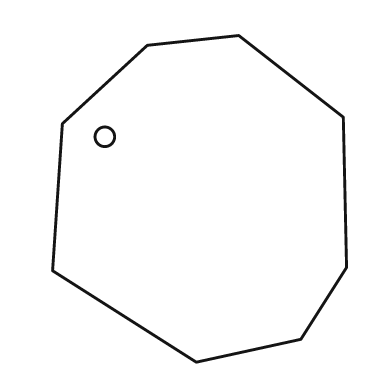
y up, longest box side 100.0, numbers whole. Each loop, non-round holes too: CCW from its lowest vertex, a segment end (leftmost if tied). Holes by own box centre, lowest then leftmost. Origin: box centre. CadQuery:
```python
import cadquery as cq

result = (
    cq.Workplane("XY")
    .moveTo(-1.0, -50.0)
    .lineTo(31.0, -43.0)
    .lineTo(45.0, -21.0)
    .lineTo(44.0, 25.0)
    .lineTo(12.0, 50.0)
    .lineTo(-16.0, 47.0)
    .lineTo(-42.0, 23.0)
    .lineTo(-45.0, -22.0)
    .close()
    .moveTo(-29.0, 19.0)
    .circle(3.0)
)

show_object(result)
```